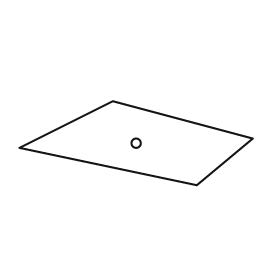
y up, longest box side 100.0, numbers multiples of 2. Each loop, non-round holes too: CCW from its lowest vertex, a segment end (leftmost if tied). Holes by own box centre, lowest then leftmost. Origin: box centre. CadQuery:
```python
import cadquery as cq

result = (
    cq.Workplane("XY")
    .moveTo(26.0, -18.0)
    .lineTo(50.0, 2.0)
    .lineTo(-10.0, 18.0)
    .lineTo(-50.0, -2.0)
    .close()
    .moveTo(0.0, 0.0)
    .circle(2.0)
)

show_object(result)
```